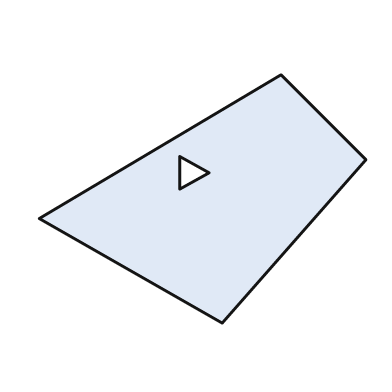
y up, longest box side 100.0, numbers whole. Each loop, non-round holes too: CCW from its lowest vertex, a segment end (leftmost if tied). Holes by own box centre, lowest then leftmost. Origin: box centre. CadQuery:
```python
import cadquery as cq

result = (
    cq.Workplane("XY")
    .moveTo(6.0, -38.0)
    .lineTo(50.0, 12.0)
    .lineTo(24.0, 38.0)
    .lineTo(-50.0, -6.0)
    .close()
    .moveTo(-7.0, 3.0)
    .lineTo(2.0, 8.0)
    .lineTo(-7.0, 13.0)
    .close()
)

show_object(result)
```